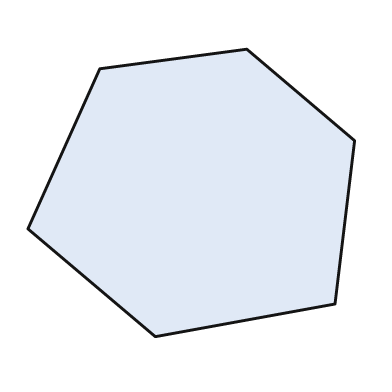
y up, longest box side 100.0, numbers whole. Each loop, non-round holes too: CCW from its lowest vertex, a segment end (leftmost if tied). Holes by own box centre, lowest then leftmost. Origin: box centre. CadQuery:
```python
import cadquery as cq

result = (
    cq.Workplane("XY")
    .moveTo(-11.0, -44.0)
    .lineTo(44.0, -34.0)
    .lineTo(50.0, 16.0)
    .lineTo(17.0, 44.0)
    .lineTo(-28.0, 38.0)
    .lineTo(-50.0, -11.0)
    .close()
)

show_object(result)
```